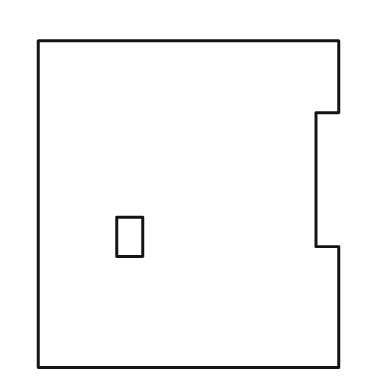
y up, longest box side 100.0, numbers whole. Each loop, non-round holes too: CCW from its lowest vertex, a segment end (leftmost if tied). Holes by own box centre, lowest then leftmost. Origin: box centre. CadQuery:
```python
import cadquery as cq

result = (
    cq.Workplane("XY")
    .moveTo(-46.0, -50.0)
    .lineTo(46.0, -50.0)
    .lineTo(46.0, -13.0)
    .lineTo(39.0, -13.0)
    .lineTo(39.0, 28.0)
    .lineTo(46.0, 28.0)
    .lineTo(46.0, 50.0)
    .lineTo(-46.0, 50.0)
    .close()
    .moveTo(-22.0, -16.0)
    .lineTo(-14.0, -16.0)
    .lineTo(-14.0, -4.0)
    .lineTo(-22.0, -4.0)
    .close()
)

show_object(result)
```